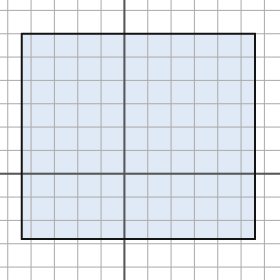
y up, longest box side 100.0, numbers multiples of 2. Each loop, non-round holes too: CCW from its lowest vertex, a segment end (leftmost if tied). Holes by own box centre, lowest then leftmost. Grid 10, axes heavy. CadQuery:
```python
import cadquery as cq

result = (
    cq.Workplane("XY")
    .moveTo(-44.0, -28.0)
    .lineTo(56.0, -28.0)
    .lineTo(56.0, 60.0)
    .lineTo(-44.0, 60.0)
    .close()
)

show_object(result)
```